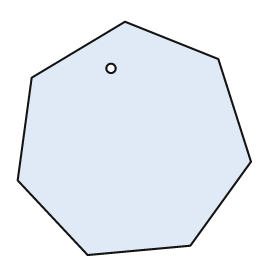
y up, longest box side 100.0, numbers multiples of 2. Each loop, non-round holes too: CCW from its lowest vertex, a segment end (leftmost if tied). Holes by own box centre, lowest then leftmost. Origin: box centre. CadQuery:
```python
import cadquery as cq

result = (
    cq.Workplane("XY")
    .moveTo(-20.0, -50.0)
    .lineTo(24.0, -46.0)
    .lineTo(50.0, -10.0)
    .lineTo(36.0, 34.0)
    .lineTo(-4.0, 50.0)
    .lineTo(-44.0, 26.0)
    .lineTo(-50.0, -18.0)
    .close()
    .moveTo(-10.0, 30.0)
    .circle(2.0)
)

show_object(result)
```